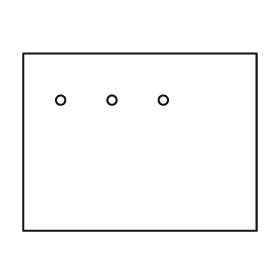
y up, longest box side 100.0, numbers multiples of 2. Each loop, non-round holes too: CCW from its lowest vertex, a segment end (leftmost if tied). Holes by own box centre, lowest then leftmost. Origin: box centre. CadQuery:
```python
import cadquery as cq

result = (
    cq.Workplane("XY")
    .moveTo(-50.0, -38.0)
    .lineTo(50.0, -38.0)
    .lineTo(50.0, 38.0)
    .lineTo(-50.0, 38.0)
    .close()
    .moveTo(-34.0, 18.0)
    .circle(2.0)
    .moveTo(-12.0, 18.0)
    .circle(2.0)
    .moveTo(10.0, 18.0)
    .circle(2.0)
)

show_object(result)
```